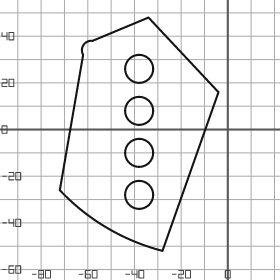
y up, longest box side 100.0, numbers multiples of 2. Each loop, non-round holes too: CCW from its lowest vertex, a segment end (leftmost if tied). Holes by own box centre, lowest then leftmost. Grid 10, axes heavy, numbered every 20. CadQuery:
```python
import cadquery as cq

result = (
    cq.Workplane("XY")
    .moveTo(-28.0, -52.0)
    .lineTo(-4.0, 16.0)
    .lineTo(-34.0, 48.0)
    .lineTo(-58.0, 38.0)
    .threePointArc((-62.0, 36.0), (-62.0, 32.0))
    .lineTo(-72.0, -26.0)
    .threePointArc((-52.0, -42.0), (-28.0, -52.0))
    .close()
    .moveTo(-38.0, -28.0)
    .circle(6.0)
    .moveTo(-38.0, -10.0)
    .circle(6.0)
    .moveTo(-38.0, 8.0)
    .circle(6.0)
    .moveTo(-38.0, 26.0)
    .circle(6.0)
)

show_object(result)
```